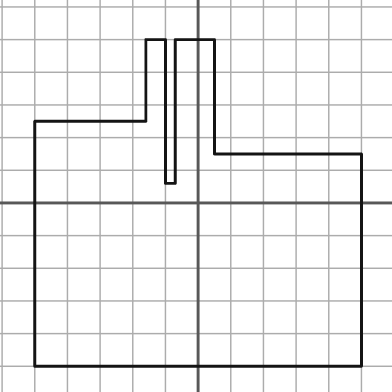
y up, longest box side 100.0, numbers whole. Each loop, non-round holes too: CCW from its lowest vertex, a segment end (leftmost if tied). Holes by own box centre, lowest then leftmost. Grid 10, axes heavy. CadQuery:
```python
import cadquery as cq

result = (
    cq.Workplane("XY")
    .moveTo(-50.0, -50.0)
    .lineTo(50.0, -50.0)
    .lineTo(50.0, 15.0)
    .lineTo(5.0, 15.0)
    .lineTo(5.0, 50.0)
    .lineTo(-7.0, 50.0)
    .lineTo(-7.0, 6.0)
    .lineTo(-10.0, 6.0)
    .lineTo(-10.0, 50.0)
    .lineTo(-16.0, 50.0)
    .lineTo(-16.0, 25.0)
    .lineTo(-50.0, 25.0)
    .close()
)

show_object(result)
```